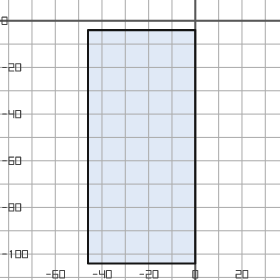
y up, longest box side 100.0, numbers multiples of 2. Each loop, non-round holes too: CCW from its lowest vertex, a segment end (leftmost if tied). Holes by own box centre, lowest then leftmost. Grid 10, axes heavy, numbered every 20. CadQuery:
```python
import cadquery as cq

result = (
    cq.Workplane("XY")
    .moveTo(-46.0, -104.0)
    .lineTo(0.0, -104.0)
    .lineTo(0.0, -4.0)
    .lineTo(-46.0, -4.0)
    .close()
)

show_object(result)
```